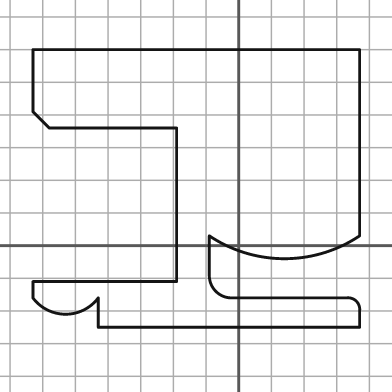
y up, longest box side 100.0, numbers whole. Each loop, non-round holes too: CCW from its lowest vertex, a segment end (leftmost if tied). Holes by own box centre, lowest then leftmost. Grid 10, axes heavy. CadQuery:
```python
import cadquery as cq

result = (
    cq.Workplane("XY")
    .moveTo(-43.0, -25.0)
    .lineTo(37.0, -25.0)
    .lineTo(37.0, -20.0)
    .threePointArc((36.0, -17.0), (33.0, -16.0))
    .lineTo(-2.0, -16.0)
    .threePointArc((-7.0, -14.0), (-9.0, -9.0))
    .lineTo(-9.0, 3.0)
    .threePointArc((14.0, -4.0), (37.0, 3.0))
    .lineTo(37.0, 60.0)
    .lineTo(-63.0, 60.0)
    .lineTo(-63.0, 41.0)
    .lineTo(-58.0, 36.0)
    .lineTo(-19.0, 36.0)
    .lineTo(-19.0, -11.0)
    .lineTo(-63.0, -11.0)
    .lineTo(-63.0, -16.0)
    .threePointArc((-53.0, -21.0), (-43.0, -16.0))
    .close()
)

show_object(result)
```